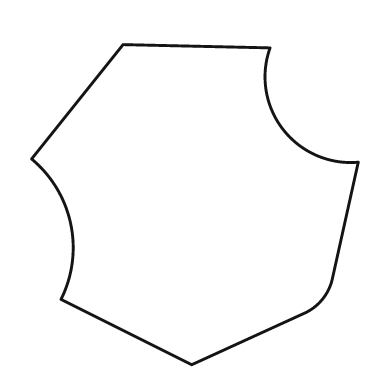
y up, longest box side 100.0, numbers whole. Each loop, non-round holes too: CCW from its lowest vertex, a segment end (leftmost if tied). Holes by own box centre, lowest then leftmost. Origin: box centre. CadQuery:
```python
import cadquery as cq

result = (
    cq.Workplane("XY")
    .moveTo(-1.0, -49.0)
    .lineTo(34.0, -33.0)
    .threePointArc((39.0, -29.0), (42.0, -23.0))
    .lineTo(50.0, 13.0)
    .threePointArc((27.0, 23.0), (23.0, 48.0))
    .lineTo(-22.0, 49.0)
    .lineTo(-50.0, 14.0)
    .threePointArc((-38.0, -6.0), (-41.0, -29.0))
    .close()
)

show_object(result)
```